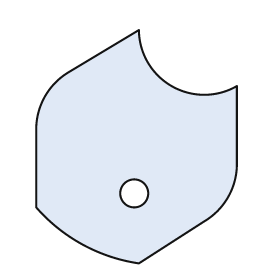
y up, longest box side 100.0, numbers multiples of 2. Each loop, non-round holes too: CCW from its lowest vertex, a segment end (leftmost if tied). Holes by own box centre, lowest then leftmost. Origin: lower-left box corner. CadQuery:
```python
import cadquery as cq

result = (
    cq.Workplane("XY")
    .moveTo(44.0, 0.0)
    .lineTo(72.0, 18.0)
    .threePointArc((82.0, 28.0), (86.0, 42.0))
    .lineTo(86.0, 76.0)
    .threePointArc((58.0, 76.0), (44.0, 100.0))
    .lineTo(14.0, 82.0)
    .threePointArc((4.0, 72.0), (0.0, 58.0))
    .lineTo(0.0, 24.0)
    .threePointArc((20.0, 8.0), (44.0, 0.0))
    .close()
    .moveTo(42.0, 30.0)
    .circle(6.0)
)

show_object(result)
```